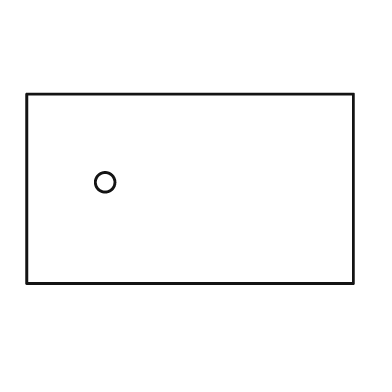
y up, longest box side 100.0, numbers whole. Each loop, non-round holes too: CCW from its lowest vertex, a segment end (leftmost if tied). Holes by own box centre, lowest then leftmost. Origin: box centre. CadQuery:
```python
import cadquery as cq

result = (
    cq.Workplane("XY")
    .moveTo(-50.0, -29.0)
    .lineTo(50.0, -29.0)
    .lineTo(50.0, 29.0)
    .lineTo(-50.0, 29.0)
    .close()
    .moveTo(-26.0, 2.0)
    .circle(3.0)
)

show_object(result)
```